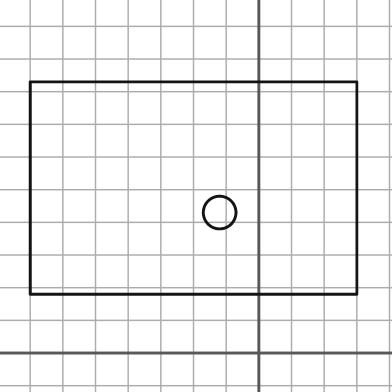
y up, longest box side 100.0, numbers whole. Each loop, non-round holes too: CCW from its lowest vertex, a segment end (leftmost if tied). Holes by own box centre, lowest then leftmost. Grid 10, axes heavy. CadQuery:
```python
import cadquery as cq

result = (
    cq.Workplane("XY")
    .moveTo(-70.0, 18.0)
    .lineTo(30.0, 18.0)
    .lineTo(30.0, 83.0)
    .lineTo(-70.0, 83.0)
    .close()
    .moveTo(-12.0, 43.0)
    .circle(5.0)
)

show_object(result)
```